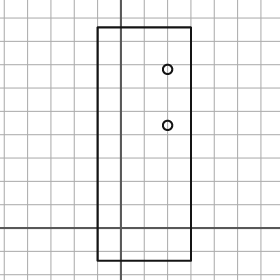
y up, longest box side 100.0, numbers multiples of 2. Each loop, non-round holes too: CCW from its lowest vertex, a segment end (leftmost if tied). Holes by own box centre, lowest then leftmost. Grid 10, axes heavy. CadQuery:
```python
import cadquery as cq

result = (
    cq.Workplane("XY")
    .moveTo(-10.0, -14.0)
    .lineTo(30.0, -14.0)
    .lineTo(30.0, 86.0)
    .lineTo(-10.0, 86.0)
    .close()
    .moveTo(20.0, 44.0)
    .circle(2.0)
    .moveTo(20.0, 68.0)
    .circle(2.0)
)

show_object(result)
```